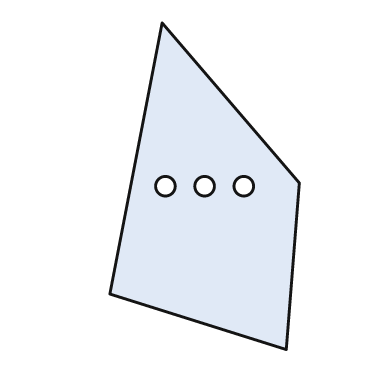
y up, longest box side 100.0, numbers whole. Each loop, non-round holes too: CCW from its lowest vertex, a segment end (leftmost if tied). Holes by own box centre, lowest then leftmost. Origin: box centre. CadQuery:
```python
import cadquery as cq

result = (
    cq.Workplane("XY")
    .moveTo(25.0, -50.0)
    .lineTo(29.0, 1.0)
    .lineTo(-13.0, 50.0)
    .lineTo(-29.0, -33.0)
    .close()
    .moveTo(-12.0, 0.0)
    .circle(3.0)
    .moveTo(0.0, 0.0)
    .circle(3.0)
    .moveTo(12.0, 0.0)
    .circle(3.0)
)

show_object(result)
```